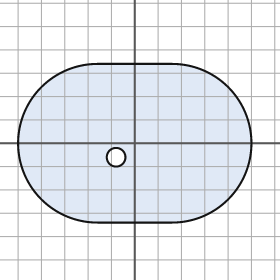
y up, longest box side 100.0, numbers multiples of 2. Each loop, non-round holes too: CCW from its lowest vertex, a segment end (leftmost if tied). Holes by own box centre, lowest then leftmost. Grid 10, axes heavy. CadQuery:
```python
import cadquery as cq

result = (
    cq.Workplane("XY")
    .moveTo(-16.0, -34.0)
    .lineTo(16.0, -34.0)
    .threePointArc((50.0, 0.0), (16.0, 34.0))
    .lineTo(-16.0, 34.0)
    .threePointArc((-50.0, 0.0), (-16.0, -34.0))
    .close()
    .moveTo(-8.0, -6.0)
    .circle(4.0)
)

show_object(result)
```